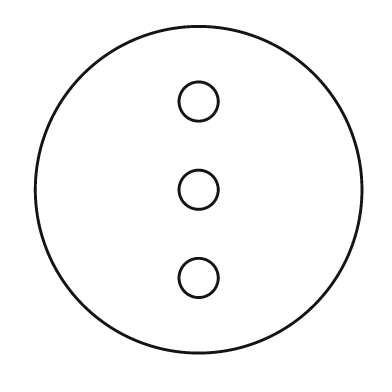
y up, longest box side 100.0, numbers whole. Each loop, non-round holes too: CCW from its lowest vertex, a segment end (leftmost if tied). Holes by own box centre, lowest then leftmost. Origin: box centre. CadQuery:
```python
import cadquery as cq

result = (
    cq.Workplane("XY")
    .moveTo(0.0, 0.0)
    .circle(50.0)
    .moveTo(0.0, -27.0)
    .circle(6.0)
    .moveTo(0.0, 0.0)
    .circle(6.0)
    .moveTo(0.0, 27.0)
    .circle(6.0)
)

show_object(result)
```